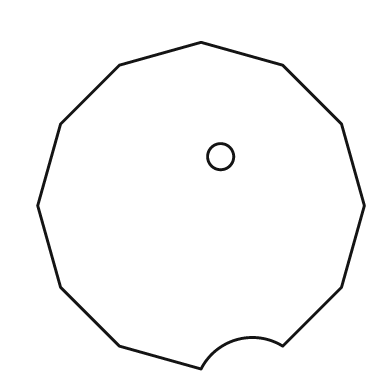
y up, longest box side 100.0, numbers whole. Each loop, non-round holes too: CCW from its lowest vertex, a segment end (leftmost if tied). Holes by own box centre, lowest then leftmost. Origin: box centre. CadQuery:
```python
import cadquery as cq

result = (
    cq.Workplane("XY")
    .moveTo(0.0, -50.0)
    .threePointArc((11.0, -41.0), (25.0, -43.0))
    .lineTo(43.0, -25.0)
    .lineTo(50.0, 0.0)
    .lineTo(43.0, 25.0)
    .lineTo(25.0, 43.0)
    .lineTo(0.0, 50.0)
    .lineTo(-25.0, 43.0)
    .lineTo(-43.0, 25.0)
    .lineTo(-50.0, 0.0)
    .lineTo(-43.0, -25.0)
    .lineTo(-25.0, -43.0)
    .close()
    .moveTo(6.0, 15.0)
    .circle(4.0)
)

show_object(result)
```